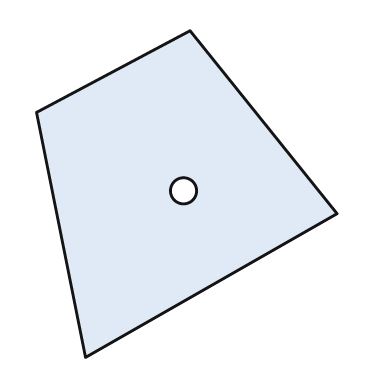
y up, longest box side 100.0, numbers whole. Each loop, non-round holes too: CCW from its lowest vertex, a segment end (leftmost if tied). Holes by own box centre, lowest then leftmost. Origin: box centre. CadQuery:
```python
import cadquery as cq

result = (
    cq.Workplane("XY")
    .moveTo(-31.0, -50.0)
    .lineTo(46.0, -6.0)
    .lineTo(1.0, 50.0)
    .lineTo(-46.0, 25.0)
    .close()
    .moveTo(-1.0, 1.0)
    .circle(4.0)
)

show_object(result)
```